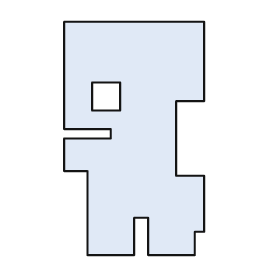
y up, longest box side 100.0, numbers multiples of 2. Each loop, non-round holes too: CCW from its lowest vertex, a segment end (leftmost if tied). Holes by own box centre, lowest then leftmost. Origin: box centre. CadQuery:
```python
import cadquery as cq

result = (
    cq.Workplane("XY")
    .moveTo(-20.0, -50.0)
    .lineTo(0.0, -50.0)
    .lineTo(0.0, -34.0)
    .lineTo(6.0, -34.0)
    .lineTo(6.0, -50.0)
    .lineTo(26.0, -50.0)
    .lineTo(26.0, -40.0)
    .lineTo(30.0, -40.0)
    .lineTo(30.0, -16.0)
    .lineTo(18.0, -16.0)
    .lineTo(18.0, 16.0)
    .lineTo(30.0, 16.0)
    .lineTo(30.0, 50.0)
    .lineTo(-30.0, 50.0)
    .lineTo(-30.0, 4.0)
    .lineTo(-10.0, 4.0)
    .lineTo(-10.0, 0.0)
    .lineTo(-30.0, 0.0)
    .lineTo(-30.0, -14.0)
    .lineTo(-20.0, -14.0)
    .close()
    .moveTo(-18.0, 12.0)
    .lineTo(-6.0, 12.0)
    .lineTo(-6.0, 24.0)
    .lineTo(-18.0, 24.0)
    .close()
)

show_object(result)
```